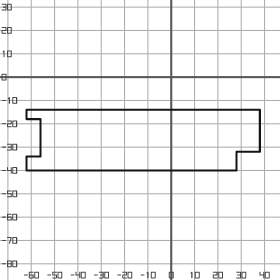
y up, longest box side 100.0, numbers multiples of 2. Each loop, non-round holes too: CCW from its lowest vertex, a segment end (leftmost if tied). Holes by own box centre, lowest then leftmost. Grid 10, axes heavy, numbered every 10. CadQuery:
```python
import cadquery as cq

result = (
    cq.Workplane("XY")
    .moveTo(-62.0, -40.0)
    .lineTo(28.0, -40.0)
    .lineTo(28.0, -32.0)
    .lineTo(38.0, -32.0)
    .lineTo(38.0, -14.0)
    .lineTo(-62.0, -14.0)
    .lineTo(-62.0, -18.0)
    .lineTo(-56.0, -18.0)
    .lineTo(-56.0, -34.0)
    .lineTo(-62.0, -34.0)
    .close()
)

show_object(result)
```